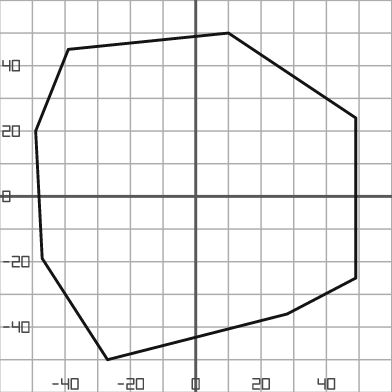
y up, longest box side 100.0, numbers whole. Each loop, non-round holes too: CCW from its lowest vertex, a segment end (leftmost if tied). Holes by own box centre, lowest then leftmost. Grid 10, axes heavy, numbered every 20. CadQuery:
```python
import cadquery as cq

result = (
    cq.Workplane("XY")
    .moveTo(-27.0, -50.0)
    .lineTo(28.0, -36.0)
    .lineTo(49.0, -25.0)
    .lineTo(49.0, 24.0)
    .lineTo(10.0, 50.0)
    .lineTo(-39.0, 45.0)
    .lineTo(-49.0, 20.0)
    .lineTo(-47.0, -19.0)
    .close()
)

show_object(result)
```